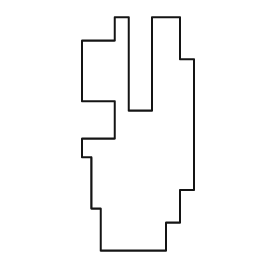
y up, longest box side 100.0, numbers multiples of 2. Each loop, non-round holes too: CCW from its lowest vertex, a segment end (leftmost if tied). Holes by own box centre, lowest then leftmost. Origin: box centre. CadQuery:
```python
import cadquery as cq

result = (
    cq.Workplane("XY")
    .moveTo(-16.0, -50.0)
    .lineTo(12.0, -50.0)
    .lineTo(12.0, -38.0)
    .lineTo(18.0, -38.0)
    .lineTo(18.0, -24.0)
    .lineTo(24.0, -24.0)
    .lineTo(24.0, 32.0)
    .lineTo(18.0, 32.0)
    .lineTo(18.0, 50.0)
    .lineTo(6.0, 50.0)
    .lineTo(6.0, 10.0)
    .lineTo(-4.0, 10.0)
    .lineTo(-4.0, 50.0)
    .lineTo(-10.0, 50.0)
    .lineTo(-10.0, 40.0)
    .lineTo(-24.0, 40.0)
    .lineTo(-24.0, 14.0)
    .lineTo(-10.0, 14.0)
    .lineTo(-10.0, -2.0)
    .lineTo(-24.0, -2.0)
    .lineTo(-24.0, -10.0)
    .lineTo(-20.0, -10.0)
    .lineTo(-20.0, -32.0)
    .lineTo(-16.0, -32.0)
    .close()
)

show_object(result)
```